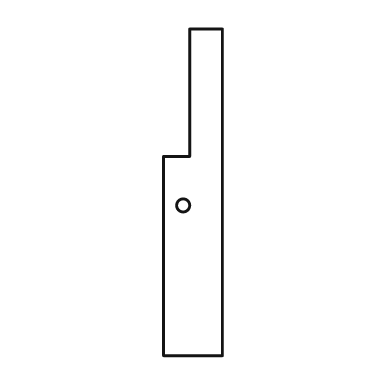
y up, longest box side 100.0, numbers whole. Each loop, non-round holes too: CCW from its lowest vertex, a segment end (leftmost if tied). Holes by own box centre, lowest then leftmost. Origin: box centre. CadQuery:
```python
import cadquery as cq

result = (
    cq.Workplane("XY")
    .moveTo(-9.0, -50.0)
    .lineTo(9.0, -50.0)
    .lineTo(9.0, 50.0)
    .lineTo(-1.0, 50.0)
    .lineTo(-1.0, 11.0)
    .lineTo(-9.0, 11.0)
    .close()
    .moveTo(-3.0, -4.0)
    .circle(2.0)
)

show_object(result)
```